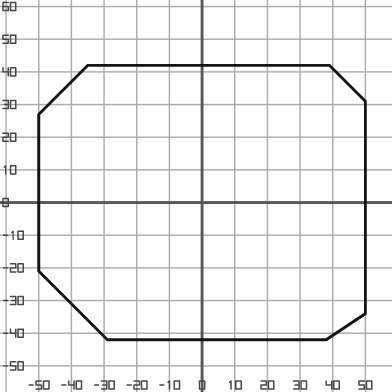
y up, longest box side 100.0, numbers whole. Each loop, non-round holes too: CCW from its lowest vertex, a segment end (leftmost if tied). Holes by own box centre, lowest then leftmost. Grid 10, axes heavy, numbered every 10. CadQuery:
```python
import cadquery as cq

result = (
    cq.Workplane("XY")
    .moveTo(-29.0, -42.0)
    .lineTo(38.0, -42.0)
    .lineTo(50.0, -34.0)
    .lineTo(50.0, 31.0)
    .lineTo(39.0, 42.0)
    .lineTo(-35.0, 42.0)
    .lineTo(-50.0, 27.0)
    .lineTo(-50.0, -21.0)
    .close()
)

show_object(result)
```